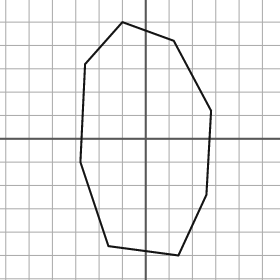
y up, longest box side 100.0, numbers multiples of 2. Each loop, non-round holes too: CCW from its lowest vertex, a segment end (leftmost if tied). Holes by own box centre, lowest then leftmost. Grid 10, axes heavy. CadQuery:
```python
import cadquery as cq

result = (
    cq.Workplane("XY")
    .moveTo(14.0, -50.0)
    .lineTo(26.0, -24.0)
    .lineTo(28.0, 12.0)
    .lineTo(12.0, 42.0)
    .lineTo(-10.0, 50.0)
    .lineTo(-26.0, 32.0)
    .lineTo(-28.0, -10.0)
    .lineTo(-16.0, -46.0)
    .close()
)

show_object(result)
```